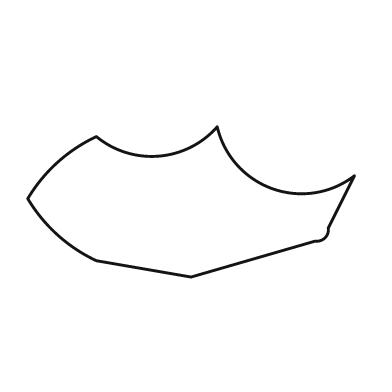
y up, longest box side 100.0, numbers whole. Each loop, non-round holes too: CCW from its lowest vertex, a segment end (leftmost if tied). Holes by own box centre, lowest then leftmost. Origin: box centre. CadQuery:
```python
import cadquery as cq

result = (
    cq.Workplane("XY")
    .moveTo(0.0, -23.0)
    .lineTo(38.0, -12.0)
    .threePointArc((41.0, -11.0), (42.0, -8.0))
    .lineTo(50.0, 8.0)
    .threePointArc((25.0, 4.0), (8.0, 23.0))
    .threePointArc((-10.0, 14.0), (-29.0, 20.0))
    .threePointArc((-41.0, 12.0), (-50.0, 1.0))
    .threePointArc((-41.0, -10.0), (-29.0, -18.0))
    .close()
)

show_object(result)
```